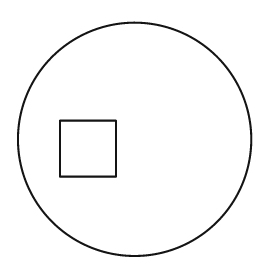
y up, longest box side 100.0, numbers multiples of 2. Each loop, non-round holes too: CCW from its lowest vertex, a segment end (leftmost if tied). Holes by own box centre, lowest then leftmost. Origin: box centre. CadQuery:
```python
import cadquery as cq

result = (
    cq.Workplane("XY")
    .moveTo(0.0, 0.0)
    .circle(50.0)
    .moveTo(-32.0, -16.0)
    .lineTo(-8.0, -16.0)
    .lineTo(-8.0, 8.0)
    .lineTo(-32.0, 8.0)
    .close()
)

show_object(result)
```